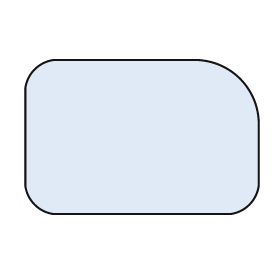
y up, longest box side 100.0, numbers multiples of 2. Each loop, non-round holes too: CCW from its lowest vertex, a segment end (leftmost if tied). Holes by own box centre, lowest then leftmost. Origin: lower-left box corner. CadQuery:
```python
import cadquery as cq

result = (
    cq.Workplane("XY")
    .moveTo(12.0, 0.0)
    .lineTo(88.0, 0.0)
    .threePointArc((96.0, 4.0), (100.0, 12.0))
    .lineTo(100.0, 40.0)
    .threePointArc((92.0, 58.0), (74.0, 66.0))
    .lineTo(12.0, 66.0)
    .threePointArc((4.0, 62.0), (0.0, 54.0))
    .lineTo(0.0, 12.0)
    .threePointArc((4.0, 4.0), (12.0, 0.0))
    .close()
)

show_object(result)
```